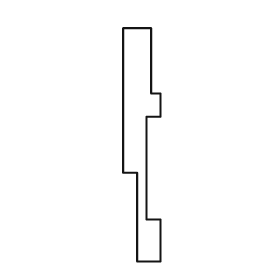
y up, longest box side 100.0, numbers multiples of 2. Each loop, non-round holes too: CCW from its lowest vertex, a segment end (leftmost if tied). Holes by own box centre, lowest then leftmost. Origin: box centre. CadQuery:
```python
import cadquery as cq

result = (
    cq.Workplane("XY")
    .moveTo(-2.0, -50.0)
    .lineTo(8.0, -50.0)
    .lineTo(8.0, -32.0)
    .lineTo(2.0, -32.0)
    .lineTo(2.0, 12.0)
    .lineTo(8.0, 12.0)
    .lineTo(8.0, 22.0)
    .lineTo(4.0, 22.0)
    .lineTo(4.0, 50.0)
    .lineTo(-8.0, 50.0)
    .lineTo(-8.0, -12.0)
    .lineTo(-2.0, -12.0)
    .close()
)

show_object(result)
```